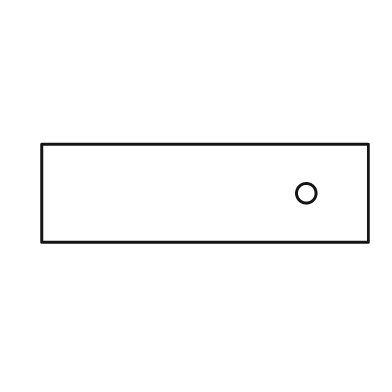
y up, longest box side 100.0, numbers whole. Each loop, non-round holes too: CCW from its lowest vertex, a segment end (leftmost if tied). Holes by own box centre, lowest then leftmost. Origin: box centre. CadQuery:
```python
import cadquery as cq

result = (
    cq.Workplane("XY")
    .moveTo(-50.0, -15.0)
    .lineTo(50.0, -15.0)
    .lineTo(50.0, 15.0)
    .lineTo(-50.0, 15.0)
    .close()
    .moveTo(31.0, 0.0)
    .circle(3.0)
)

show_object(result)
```